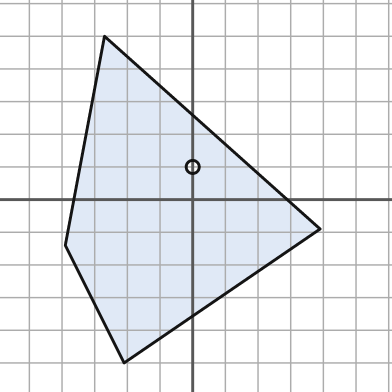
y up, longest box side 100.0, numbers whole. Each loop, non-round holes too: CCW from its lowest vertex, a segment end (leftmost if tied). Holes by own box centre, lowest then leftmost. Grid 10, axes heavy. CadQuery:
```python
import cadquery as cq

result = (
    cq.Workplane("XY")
    .moveTo(-21.0, -50.0)
    .lineTo(39.0, -9.0)
    .lineTo(-27.0, 50.0)
    .lineTo(-39.0, -14.0)
    .close()
    .moveTo(0.0, 10.0)
    .circle(2.0)
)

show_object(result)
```